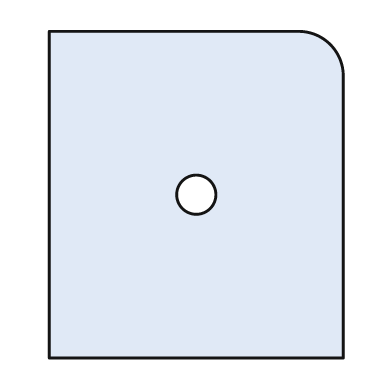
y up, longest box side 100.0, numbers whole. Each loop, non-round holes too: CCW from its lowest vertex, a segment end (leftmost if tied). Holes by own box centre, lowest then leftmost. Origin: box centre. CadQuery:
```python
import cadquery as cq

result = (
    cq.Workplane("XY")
    .moveTo(-45.0, -50.0)
    .lineTo(45.0, -50.0)
    .lineTo(45.0, 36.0)
    .threePointArc((41.0, 46.0), (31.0, 50.0))
    .lineTo(-45.0, 50.0)
    .close()
    .moveTo(0.0, 0.0)
    .circle(6.0)
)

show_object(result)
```